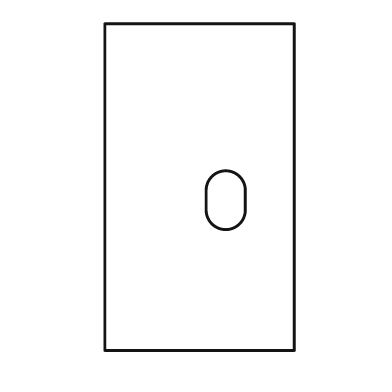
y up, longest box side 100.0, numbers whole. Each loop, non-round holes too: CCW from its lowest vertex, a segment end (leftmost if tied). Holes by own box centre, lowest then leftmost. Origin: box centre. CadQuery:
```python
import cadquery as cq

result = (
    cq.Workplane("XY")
    .moveTo(-29.0, -50.0)
    .lineTo(29.0, -50.0)
    .lineTo(29.0, 50.0)
    .lineTo(-29.0, 50.0)
    .close()
    .moveTo(2.0, -7.0)
    .threePointArc((8.0, -13.0), (14.0, -7.0))
    .lineTo(14.0, -1.0)
    .threePointArc((8.0, 5.0), (2.0, -1.0))
    .close()
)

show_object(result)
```